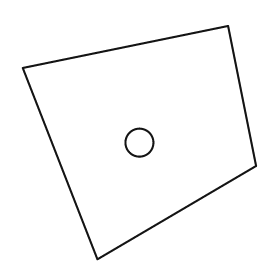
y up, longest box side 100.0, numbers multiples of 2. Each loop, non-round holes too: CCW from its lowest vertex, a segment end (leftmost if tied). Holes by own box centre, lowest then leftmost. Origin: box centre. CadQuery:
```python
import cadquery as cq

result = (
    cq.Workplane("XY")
    .moveTo(-18.0, -50.0)
    .lineTo(50.0, -10.0)
    .lineTo(38.0, 50.0)
    .lineTo(-50.0, 32.0)
    .close()
    .moveTo(0.0, 0.0)
    .circle(6.0)
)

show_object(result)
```